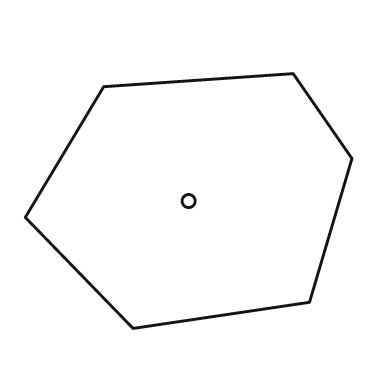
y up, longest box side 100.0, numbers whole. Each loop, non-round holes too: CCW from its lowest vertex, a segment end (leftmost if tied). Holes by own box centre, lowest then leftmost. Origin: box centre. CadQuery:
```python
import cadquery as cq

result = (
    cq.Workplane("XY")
    .moveTo(-17.0, -39.0)
    .lineTo(37.0, -31.0)
    .lineTo(50.0, 13.0)
    .lineTo(32.0, 39.0)
    .lineTo(-26.0, 35.0)
    .lineTo(-50.0, -5.0)
    .close()
    .moveTo(0.0, 0.0)
    .circle(2.0)
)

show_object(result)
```